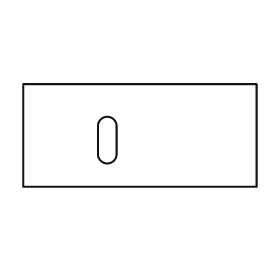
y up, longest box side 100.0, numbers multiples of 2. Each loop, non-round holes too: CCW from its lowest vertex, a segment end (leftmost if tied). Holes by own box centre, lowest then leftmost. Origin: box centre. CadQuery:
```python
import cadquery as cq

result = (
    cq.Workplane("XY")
    .moveTo(-50.0, -22.0)
    .lineTo(50.0, -22.0)
    .lineTo(50.0, 22.0)
    .lineTo(-50.0, 22.0)
    .close()
    .moveTo(-18.0, -8.0)
    .threePointArc((-14.0, -12.0), (-10.0, -8.0))
    .lineTo(-10.0, 4.0)
    .threePointArc((-14.0, 8.0), (-18.0, 4.0))
    .close()
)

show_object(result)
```